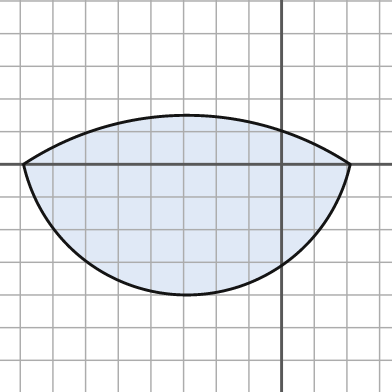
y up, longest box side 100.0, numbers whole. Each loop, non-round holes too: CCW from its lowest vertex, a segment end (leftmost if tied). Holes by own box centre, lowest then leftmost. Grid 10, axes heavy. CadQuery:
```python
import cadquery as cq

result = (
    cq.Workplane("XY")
    .moveTo(-79.0, 0.0)
    .threePointArc((-29.0, -40.0), (21.0, 0.0))
    .threePointArc((-29.0, 15.0), (-79.0, 0.0))
    .close()
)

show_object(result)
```